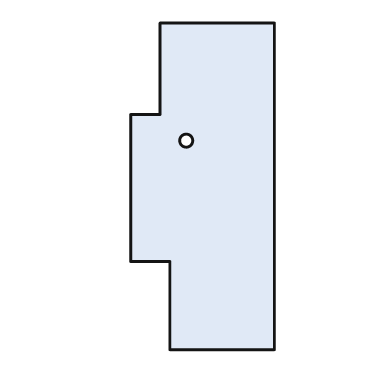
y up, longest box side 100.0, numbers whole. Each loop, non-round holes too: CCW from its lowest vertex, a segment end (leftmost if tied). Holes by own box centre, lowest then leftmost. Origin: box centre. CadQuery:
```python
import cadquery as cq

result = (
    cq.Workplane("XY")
    .moveTo(-10.0, -50.0)
    .lineTo(22.0, -50.0)
    .lineTo(22.0, 50.0)
    .lineTo(-13.0, 50.0)
    .lineTo(-13.0, 22.0)
    .lineTo(-22.0, 22.0)
    .lineTo(-22.0, -23.0)
    .lineTo(-10.0, -23.0)
    .close()
    .moveTo(-5.0, 14.0)
    .circle(2.0)
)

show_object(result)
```